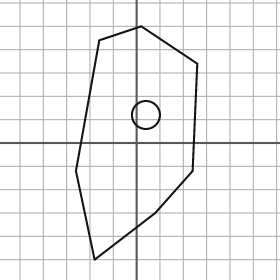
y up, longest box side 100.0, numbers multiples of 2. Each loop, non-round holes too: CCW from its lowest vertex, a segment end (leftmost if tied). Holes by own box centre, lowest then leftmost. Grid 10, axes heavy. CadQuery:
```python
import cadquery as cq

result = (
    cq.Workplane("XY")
    .moveTo(-18.0, -50.0)
    .lineTo(8.0, -30.0)
    .lineTo(24.0, -12.0)
    .lineTo(26.0, 34.0)
    .lineTo(2.0, 50.0)
    .lineTo(-16.0, 44.0)
    .lineTo(-26.0, -12.0)
    .close()
    .moveTo(4.0, 12.0)
    .circle(6.0)
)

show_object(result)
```